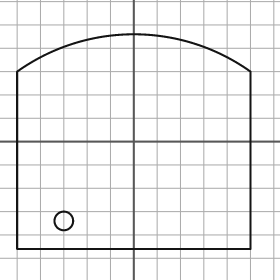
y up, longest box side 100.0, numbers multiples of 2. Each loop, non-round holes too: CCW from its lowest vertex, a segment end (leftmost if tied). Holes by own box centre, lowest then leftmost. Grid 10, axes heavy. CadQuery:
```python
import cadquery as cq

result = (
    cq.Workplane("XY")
    .moveTo(-50.0, -46.0)
    .lineTo(50.0, -46.0)
    .lineTo(50.0, 30.0)
    .threePointArc((0.0, 46.0), (-50.0, 30.0))
    .close()
    .moveTo(-30.0, -34.0)
    .circle(4.0)
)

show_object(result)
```